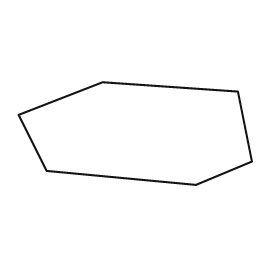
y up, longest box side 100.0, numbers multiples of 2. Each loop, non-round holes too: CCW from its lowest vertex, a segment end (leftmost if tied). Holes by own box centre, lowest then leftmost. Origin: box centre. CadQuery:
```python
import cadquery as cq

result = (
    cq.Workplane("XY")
    .moveTo(26.0, -22.0)
    .lineTo(50.0, -12.0)
    .lineTo(44.0, 18.0)
    .lineTo(-14.0, 22.0)
    .lineTo(-50.0, 8.0)
    .lineTo(-38.0, -16.0)
    .close()
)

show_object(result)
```